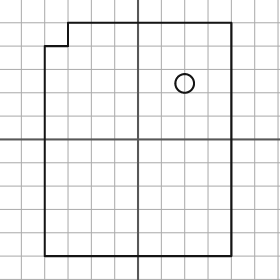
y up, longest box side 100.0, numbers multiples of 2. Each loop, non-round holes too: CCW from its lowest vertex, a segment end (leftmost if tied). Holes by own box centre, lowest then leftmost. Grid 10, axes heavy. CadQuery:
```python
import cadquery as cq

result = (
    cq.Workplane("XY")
    .moveTo(-40.0, -50.0)
    .lineTo(40.0, -50.0)
    .lineTo(40.0, 50.0)
    .lineTo(-30.0, 50.0)
    .lineTo(-30.0, 40.0)
    .lineTo(-40.0, 40.0)
    .close()
    .moveTo(20.0, 24.0)
    .circle(4.0)
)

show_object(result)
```